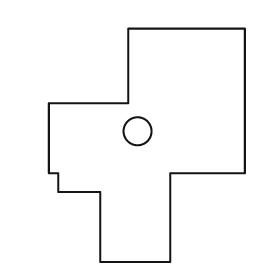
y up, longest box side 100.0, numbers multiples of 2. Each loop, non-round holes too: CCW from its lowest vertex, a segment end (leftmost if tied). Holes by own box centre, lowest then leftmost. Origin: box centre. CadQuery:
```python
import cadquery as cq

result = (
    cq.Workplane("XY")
    .moveTo(-20.0, -50.0)
    .lineTo(10.0, -50.0)
    .lineTo(10.0, -12.0)
    .lineTo(42.0, -12.0)
    .lineTo(42.0, 50.0)
    .lineTo(-8.0, 50.0)
    .lineTo(-8.0, 18.0)
    .lineTo(-42.0, 18.0)
    .lineTo(-42.0, -12.0)
    .lineTo(-38.0, -12.0)
    .lineTo(-38.0, -20.0)
    .lineTo(-20.0, -20.0)
    .close()
    .moveTo(-4.0, 6.0)
    .circle(6.0)
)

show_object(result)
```